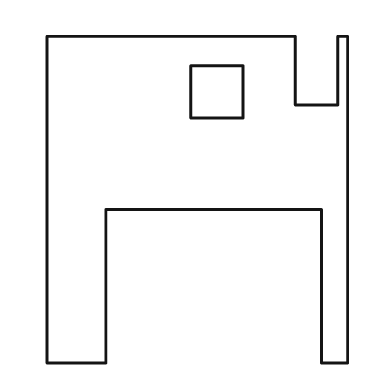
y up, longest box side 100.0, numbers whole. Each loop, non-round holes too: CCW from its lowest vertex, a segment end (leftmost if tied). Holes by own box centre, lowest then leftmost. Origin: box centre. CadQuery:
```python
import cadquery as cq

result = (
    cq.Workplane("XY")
    .moveTo(-46.0, -50.0)
    .lineTo(-28.0, -50.0)
    .lineTo(-28.0, -3.0)
    .lineTo(38.0, -3.0)
    .lineTo(38.0, -50.0)
    .lineTo(46.0, -50.0)
    .lineTo(46.0, 50.0)
    .lineTo(43.0, 50.0)
    .lineTo(43.0, 29.0)
    .lineTo(30.0, 29.0)
    .lineTo(30.0, 50.0)
    .lineTo(-46.0, 50.0)
    .close()
    .moveTo(-2.0, 25.0)
    .lineTo(14.0, 25.0)
    .lineTo(14.0, 41.0)
    .lineTo(-2.0, 41.0)
    .close()
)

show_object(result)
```